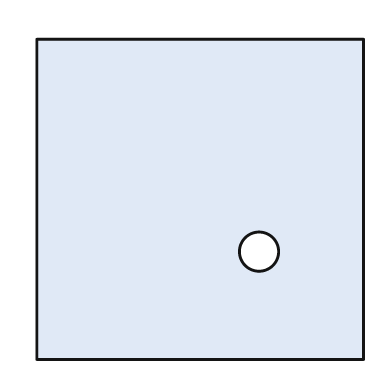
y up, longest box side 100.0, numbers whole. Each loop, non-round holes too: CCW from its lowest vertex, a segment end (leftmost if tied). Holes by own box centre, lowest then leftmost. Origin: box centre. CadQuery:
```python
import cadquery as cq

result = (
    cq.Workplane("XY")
    .moveTo(-50.0, -49.0)
    .lineTo(50.0, -49.0)
    .lineTo(50.0, 49.0)
    .lineTo(-50.0, 49.0)
    .close()
    .moveTo(18.0, -16.0)
    .circle(6.0)
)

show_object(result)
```